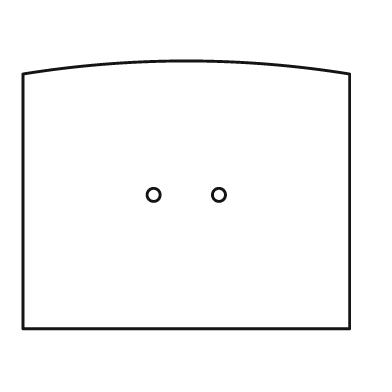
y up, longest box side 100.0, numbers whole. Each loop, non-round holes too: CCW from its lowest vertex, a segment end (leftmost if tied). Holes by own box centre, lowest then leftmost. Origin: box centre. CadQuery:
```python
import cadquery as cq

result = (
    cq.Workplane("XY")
    .moveTo(-50.0, -41.0)
    .lineTo(50.0, -41.0)
    .lineTo(50.0, 37.0)
    .threePointArc((0.0, 41.0), (-50.0, 37.0))
    .close()
    .moveTo(-10.0, 0.0)
    .circle(2.0)
    .moveTo(10.0, 0.0)
    .circle(2.0)
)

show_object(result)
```